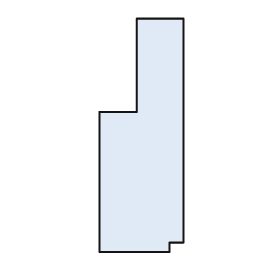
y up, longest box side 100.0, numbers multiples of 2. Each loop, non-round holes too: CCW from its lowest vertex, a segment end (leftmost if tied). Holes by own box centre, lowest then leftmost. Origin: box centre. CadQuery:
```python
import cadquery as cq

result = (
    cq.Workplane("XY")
    .moveTo(-18.0, -50.0)
    .lineTo(12.0, -50.0)
    .lineTo(12.0, -46.0)
    .lineTo(18.0, -46.0)
    .lineTo(18.0, 50.0)
    .lineTo(-2.0, 50.0)
    .lineTo(-2.0, 10.0)
    .lineTo(-18.0, 10.0)
    .close()
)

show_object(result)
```